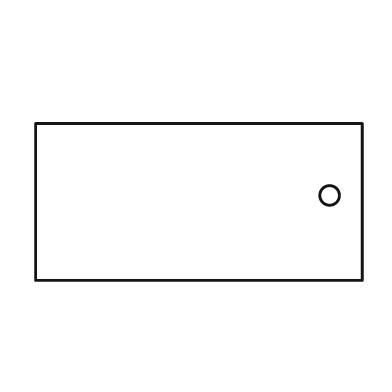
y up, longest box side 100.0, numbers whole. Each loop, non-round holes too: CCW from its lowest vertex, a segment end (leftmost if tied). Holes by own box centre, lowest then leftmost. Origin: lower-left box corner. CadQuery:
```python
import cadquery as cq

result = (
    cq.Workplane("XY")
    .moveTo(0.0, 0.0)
    .lineTo(100.0, 0.0)
    .lineTo(100.0, 48.0)
    .lineTo(0.0, 48.0)
    .close()
    .moveTo(90.0, 26.0)
    .circle(3.0)
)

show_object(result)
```